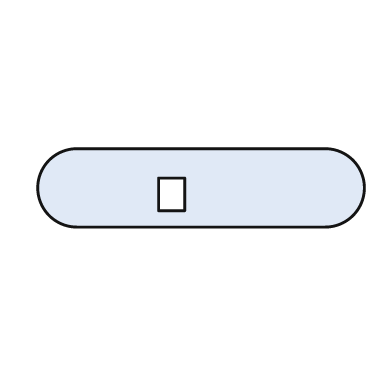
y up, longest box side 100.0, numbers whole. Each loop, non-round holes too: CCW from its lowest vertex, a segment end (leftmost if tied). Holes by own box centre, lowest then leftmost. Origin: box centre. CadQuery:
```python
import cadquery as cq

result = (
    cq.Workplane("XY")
    .moveTo(-38.0, -12.0)
    .lineTo(38.0, -12.0)
    .threePointArc((50.0, 0.0), (38.0, 12.0))
    .lineTo(-38.0, 12.0)
    .threePointArc((-50.0, 0.0), (-38.0, -12.0))
    .close()
    .moveTo(-13.0, -7.0)
    .lineTo(-5.0, -7.0)
    .lineTo(-5.0, 3.0)
    .lineTo(-13.0, 3.0)
    .close()
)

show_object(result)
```